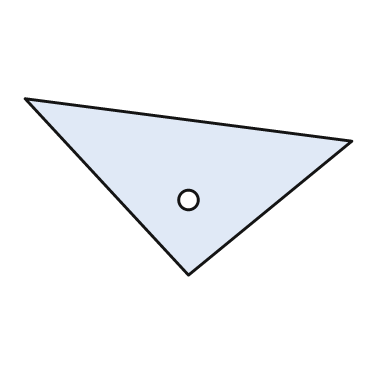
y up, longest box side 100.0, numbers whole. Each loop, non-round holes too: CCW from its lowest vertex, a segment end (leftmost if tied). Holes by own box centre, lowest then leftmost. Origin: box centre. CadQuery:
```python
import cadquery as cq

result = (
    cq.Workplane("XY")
    .moveTo(0.0, -27.0)
    .lineTo(50.0, 14.0)
    .lineTo(-50.0, 27.0)
    .close()
    .moveTo(0.0, -4.0)
    .circle(3.0)
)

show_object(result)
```